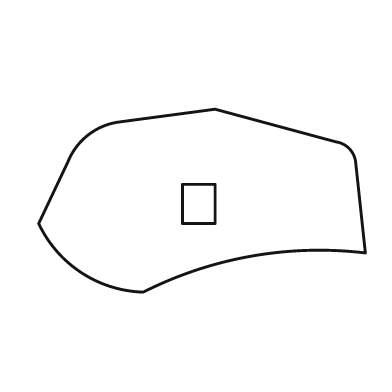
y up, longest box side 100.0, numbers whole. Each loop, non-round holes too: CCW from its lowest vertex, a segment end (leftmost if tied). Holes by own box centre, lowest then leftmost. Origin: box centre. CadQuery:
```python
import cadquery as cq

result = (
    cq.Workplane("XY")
    .moveTo(-18.0, -28.0)
    .threePointArc((15.0, -17.0), (50.0, -16.0))
    .lineTo(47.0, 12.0)
    .threePointArc((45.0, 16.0), (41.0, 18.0))
    .lineTo(4.0, 28.0)
    .lineTo(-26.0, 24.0)
    .threePointArc((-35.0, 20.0), (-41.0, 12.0))
    .lineTo(-50.0, -7.0)
    .threePointArc((-37.0, -22.0), (-18.0, -28.0))
    .close()
    .moveTo(-6.0, -7.0)
    .lineTo(4.0, -7.0)
    .lineTo(4.0, 5.0)
    .lineTo(-6.0, 5.0)
    .close()
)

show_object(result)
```